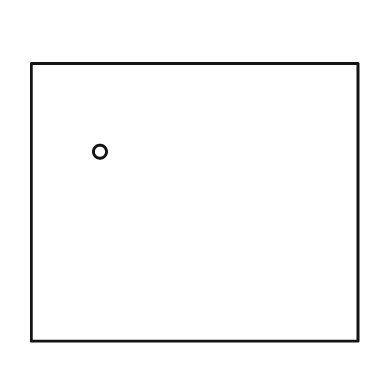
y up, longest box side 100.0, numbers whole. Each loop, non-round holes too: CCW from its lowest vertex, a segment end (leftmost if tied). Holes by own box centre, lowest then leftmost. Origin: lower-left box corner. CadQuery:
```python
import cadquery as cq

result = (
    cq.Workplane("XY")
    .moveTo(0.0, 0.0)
    .lineTo(100.0, 0.0)
    .lineTo(100.0, 85.0)
    .lineTo(0.0, 85.0)
    .close()
    .moveTo(21.0, 58.0)
    .circle(2.0)
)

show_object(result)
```